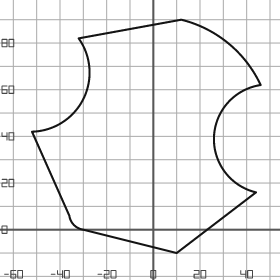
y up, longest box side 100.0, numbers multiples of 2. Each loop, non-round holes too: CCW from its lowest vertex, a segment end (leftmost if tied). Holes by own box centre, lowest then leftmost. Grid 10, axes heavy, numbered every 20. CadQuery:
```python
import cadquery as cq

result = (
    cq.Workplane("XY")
    .moveTo(10.0, -10.0)
    .lineTo(44.0, 16.0)
    .threePointArc((26.0, 40.0), (46.0, 62.0))
    .threePointArc((32.0, 80.0), (12.0, 90.0))
    .lineTo(-32.0, 82.0)
    .threePointArc((-30.0, 56.0), (-52.0, 42.0))
    .lineTo(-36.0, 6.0)
    .threePointArc((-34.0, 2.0), (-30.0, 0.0))
    .close()
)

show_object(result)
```